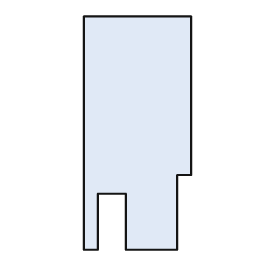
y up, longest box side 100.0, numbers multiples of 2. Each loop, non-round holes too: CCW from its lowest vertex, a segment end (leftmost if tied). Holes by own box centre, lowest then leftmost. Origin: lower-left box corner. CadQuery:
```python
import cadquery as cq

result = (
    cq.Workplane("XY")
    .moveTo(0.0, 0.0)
    .lineTo(6.0, 0.0)
    .lineTo(6.0, 24.0)
    .lineTo(18.0, 24.0)
    .lineTo(18.0, 0.0)
    .lineTo(40.0, 0.0)
    .lineTo(40.0, 32.0)
    .lineTo(46.0, 32.0)
    .lineTo(46.0, 100.0)
    .lineTo(0.0, 100.0)
    .close()
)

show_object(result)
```